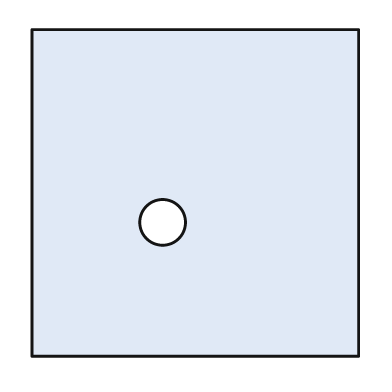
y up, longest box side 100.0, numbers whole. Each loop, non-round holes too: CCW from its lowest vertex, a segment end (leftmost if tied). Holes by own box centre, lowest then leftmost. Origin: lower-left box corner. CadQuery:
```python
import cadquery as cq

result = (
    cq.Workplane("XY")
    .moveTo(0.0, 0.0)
    .lineTo(100.0, 0.0)
    .lineTo(100.0, 100.0)
    .lineTo(0.0, 100.0)
    .close()
    .moveTo(40.0, 41.0)
    .circle(7.0)
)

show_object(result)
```